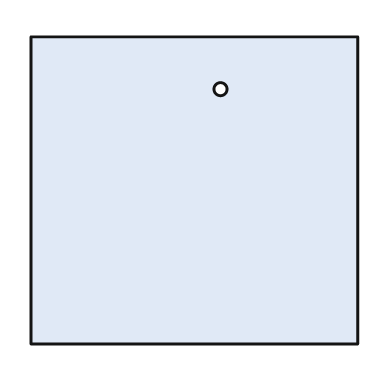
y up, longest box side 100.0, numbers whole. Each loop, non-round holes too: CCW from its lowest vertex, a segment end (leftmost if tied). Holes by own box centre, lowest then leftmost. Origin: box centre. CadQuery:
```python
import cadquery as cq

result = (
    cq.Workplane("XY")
    .moveTo(-50.0, -47.0)
    .lineTo(50.0, -47.0)
    .lineTo(50.0, 47.0)
    .lineTo(-50.0, 47.0)
    .close()
    .moveTo(8.0, 31.0)
    .circle(2.0)
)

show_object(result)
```